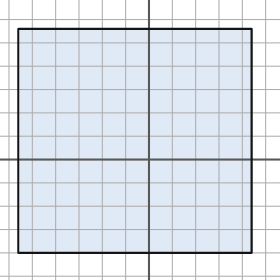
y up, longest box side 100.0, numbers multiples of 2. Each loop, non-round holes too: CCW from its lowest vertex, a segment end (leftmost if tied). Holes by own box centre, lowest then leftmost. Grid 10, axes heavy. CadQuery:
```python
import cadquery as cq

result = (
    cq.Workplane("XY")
    .moveTo(-56.0, -40.0)
    .lineTo(44.0, -40.0)
    .lineTo(44.0, 56.0)
    .lineTo(-56.0, 56.0)
    .close()
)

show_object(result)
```